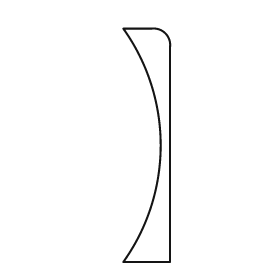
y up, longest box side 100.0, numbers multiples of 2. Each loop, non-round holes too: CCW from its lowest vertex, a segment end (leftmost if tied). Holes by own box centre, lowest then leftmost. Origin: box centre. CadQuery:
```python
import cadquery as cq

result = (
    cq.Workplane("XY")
    .moveTo(-10.0, -50.0)
    .lineTo(10.0, -50.0)
    .lineTo(10.0, 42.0)
    .threePointArc((8.0, 48.0), (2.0, 50.0))
    .lineTo(-10.0, 50.0)
    .threePointArc((6.0, 0.0), (-10.0, -50.0))
    .close()
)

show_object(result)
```